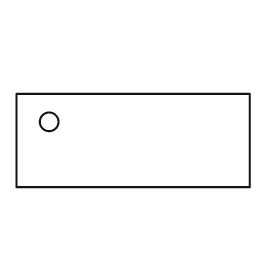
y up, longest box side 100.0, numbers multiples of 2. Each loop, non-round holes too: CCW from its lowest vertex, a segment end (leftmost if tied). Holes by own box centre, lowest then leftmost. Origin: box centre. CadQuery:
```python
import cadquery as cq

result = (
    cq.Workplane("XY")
    .moveTo(-50.0, -20.0)
    .lineTo(50.0, -20.0)
    .lineTo(50.0, 20.0)
    .lineTo(-50.0, 20.0)
    .close()
    .moveTo(-36.0, 8.0)
    .circle(4.0)
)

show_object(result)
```